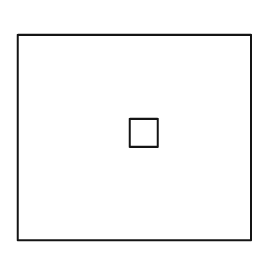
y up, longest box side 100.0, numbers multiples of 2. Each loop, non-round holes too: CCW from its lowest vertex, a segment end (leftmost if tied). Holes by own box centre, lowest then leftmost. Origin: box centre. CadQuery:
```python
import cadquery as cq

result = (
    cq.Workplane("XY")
    .moveTo(-50.0, -44.0)
    .lineTo(50.0, -44.0)
    .lineTo(50.0, 44.0)
    .lineTo(-50.0, 44.0)
    .close()
    .moveTo(-2.0, -4.0)
    .lineTo(10.0, -4.0)
    .lineTo(10.0, 8.0)
    .lineTo(-2.0, 8.0)
    .close()
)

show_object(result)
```